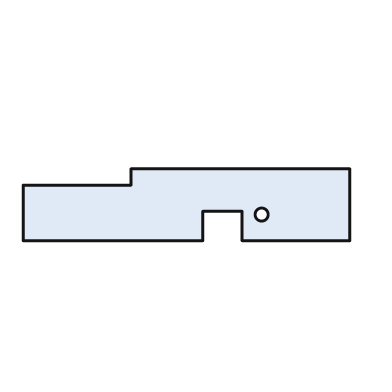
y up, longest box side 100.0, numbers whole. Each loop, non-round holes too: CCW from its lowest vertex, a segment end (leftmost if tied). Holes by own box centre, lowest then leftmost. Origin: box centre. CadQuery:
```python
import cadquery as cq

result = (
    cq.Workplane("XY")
    .moveTo(-50.0, -11.0)
    .lineTo(5.0, -11.0)
    .lineTo(5.0, -2.0)
    .lineTo(17.0, -2.0)
    .lineTo(17.0, -11.0)
    .lineTo(50.0, -11.0)
    .lineTo(50.0, 11.0)
    .lineTo(-17.0, 11.0)
    .lineTo(-17.0, 6.0)
    .lineTo(-50.0, 6.0)
    .close()
    .moveTo(23.0, -3.0)
    .circle(2.0)
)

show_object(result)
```